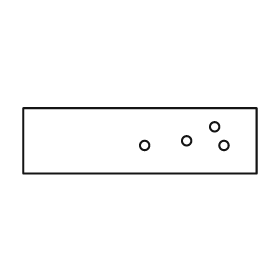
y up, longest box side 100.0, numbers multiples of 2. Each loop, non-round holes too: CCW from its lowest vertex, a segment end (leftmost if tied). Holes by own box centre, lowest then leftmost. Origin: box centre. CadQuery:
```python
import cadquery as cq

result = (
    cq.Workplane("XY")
    .moveTo(-50.0, -14.0)
    .lineTo(50.0, -14.0)
    .lineTo(50.0, 14.0)
    .lineTo(-50.0, 14.0)
    .close()
    .moveTo(2.0, -2.0)
    .circle(2.0)
    .moveTo(36.0, -2.0)
    .circle(2.0)
    .moveTo(20.0, 0.0)
    .circle(2.0)
    .moveTo(32.0, 6.0)
    .circle(2.0)
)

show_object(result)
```